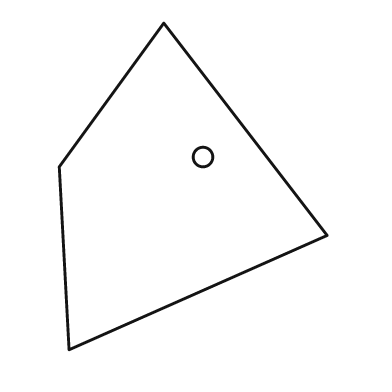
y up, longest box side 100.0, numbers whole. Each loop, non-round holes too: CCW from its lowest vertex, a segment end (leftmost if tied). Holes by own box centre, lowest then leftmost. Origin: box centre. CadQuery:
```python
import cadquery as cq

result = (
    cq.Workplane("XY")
    .moveTo(-38.0, -50.0)
    .lineTo(41.0, -15.0)
    .lineTo(-9.0, 50.0)
    .lineTo(-41.0, 6.0)
    .close()
    .moveTo(3.0, 9.0)
    .circle(3.0)
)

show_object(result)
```